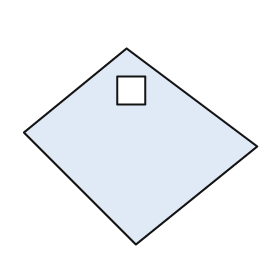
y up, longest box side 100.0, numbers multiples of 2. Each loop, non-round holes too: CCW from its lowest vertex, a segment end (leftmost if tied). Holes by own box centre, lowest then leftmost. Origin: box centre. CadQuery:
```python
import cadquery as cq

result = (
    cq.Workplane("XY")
    .moveTo(-2.0, -42.0)
    .lineTo(50.0, 0.0)
    .lineTo(-6.0, 42.0)
    .lineTo(-50.0, 6.0)
    .close()
    .moveTo(-10.0, 18.0)
    .lineTo(2.0, 18.0)
    .lineTo(2.0, 30.0)
    .lineTo(-10.0, 30.0)
    .close()
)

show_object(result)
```